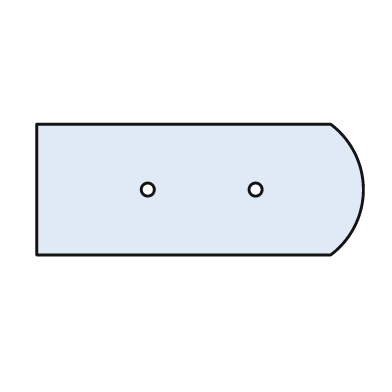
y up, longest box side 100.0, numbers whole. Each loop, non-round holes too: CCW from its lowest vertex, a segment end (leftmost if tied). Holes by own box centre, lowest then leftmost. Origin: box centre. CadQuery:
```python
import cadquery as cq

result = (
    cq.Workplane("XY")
    .moveTo(-50.0, -20.0)
    .lineTo(40.0, -20.0)
    .threePointArc((50.0, 0.0), (40.0, 20.0))
    .lineTo(-50.0, 20.0)
    .close()
    .moveTo(-16.0, 0.0)
    .circle(2.0)
    .moveTo(17.0, 0.0)
    .circle(2.0)
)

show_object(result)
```